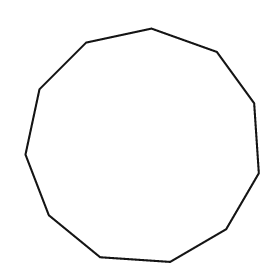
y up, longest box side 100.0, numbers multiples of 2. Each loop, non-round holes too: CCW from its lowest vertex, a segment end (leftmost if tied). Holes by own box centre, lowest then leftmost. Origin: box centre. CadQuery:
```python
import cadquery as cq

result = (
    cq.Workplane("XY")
    .moveTo(12.0, -50.0)
    .lineTo(36.0, -36.0)
    .lineTo(50.0, -12.0)
    .lineTo(48.0, 18.0)
    .lineTo(32.0, 40.0)
    .lineTo(4.0, 50.0)
    .lineTo(-24.0, 44.0)
    .lineTo(-44.0, 24.0)
    .lineTo(-50.0, -4.0)
    .lineTo(-40.0, -30.0)
    .lineTo(-18.0, -48.0)
    .close()
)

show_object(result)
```